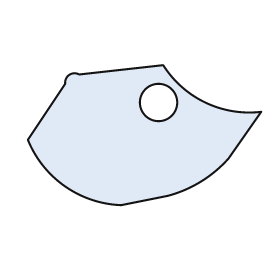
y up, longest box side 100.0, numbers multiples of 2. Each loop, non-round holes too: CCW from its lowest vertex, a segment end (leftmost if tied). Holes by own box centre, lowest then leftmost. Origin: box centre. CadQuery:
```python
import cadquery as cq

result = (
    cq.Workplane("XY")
    .moveTo(-10.0, -30.0)
    .lineTo(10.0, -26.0)
    .threePointArc((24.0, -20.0), (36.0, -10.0))
    .lineTo(50.0, 10.0)
    .threePointArc((26.0, 14.0), (8.0, 30.0))
    .lineTo(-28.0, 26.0)
    .threePointArc((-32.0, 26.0), (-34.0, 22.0))
    .lineTo(-50.0, -2.0)
    .threePointArc((-34.0, -22.0), (-10.0, -30.0))
    .close()
    .moveTo(6.0, 14.0)
    .circle(8.0)
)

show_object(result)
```